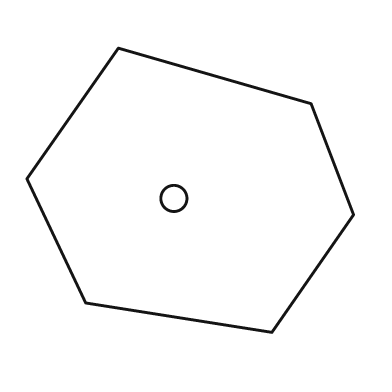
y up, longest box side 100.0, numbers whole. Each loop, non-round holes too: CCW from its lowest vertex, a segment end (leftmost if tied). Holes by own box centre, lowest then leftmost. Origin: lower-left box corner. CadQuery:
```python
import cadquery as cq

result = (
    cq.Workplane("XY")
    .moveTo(75.0, 0.0)
    .lineTo(100.0, 36.0)
    .lineTo(87.0, 70.0)
    .lineTo(28.0, 87.0)
    .lineTo(0.0, 47.0)
    .lineTo(18.0, 9.0)
    .close()
    .moveTo(45.0, 41.0)
    .circle(4.0)
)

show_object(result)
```